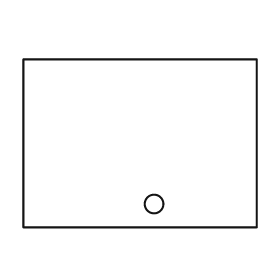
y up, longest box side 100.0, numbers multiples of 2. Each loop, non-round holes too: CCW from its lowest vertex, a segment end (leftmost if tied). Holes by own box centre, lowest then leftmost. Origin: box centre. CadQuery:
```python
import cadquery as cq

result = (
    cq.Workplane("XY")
    .moveTo(-50.0, -36.0)
    .lineTo(50.0, -36.0)
    .lineTo(50.0, 36.0)
    .lineTo(-50.0, 36.0)
    .close()
    .moveTo(6.0, -26.0)
    .circle(4.0)
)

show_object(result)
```